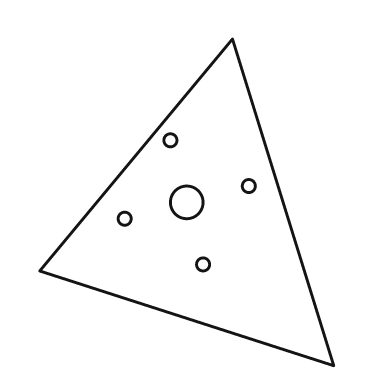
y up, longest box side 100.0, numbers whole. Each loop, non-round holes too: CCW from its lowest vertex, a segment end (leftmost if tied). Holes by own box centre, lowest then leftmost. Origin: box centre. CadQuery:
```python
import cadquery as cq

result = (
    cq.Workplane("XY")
    .moveTo(45.0, -50.0)
    .lineTo(14.0, 50.0)
    .lineTo(-45.0, -21.0)
    .close()
    .moveTo(5.0, -19.0)
    .circle(2.0)
    .moveTo(-19.0, -5.0)
    .circle(2.0)
    .moveTo(0.0, 0.0)
    .circle(5.0)
    .moveTo(19.0, 5.0)
    .circle(2.0)
    .moveTo(-5.0, 19.0)
    .circle(2.0)
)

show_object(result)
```